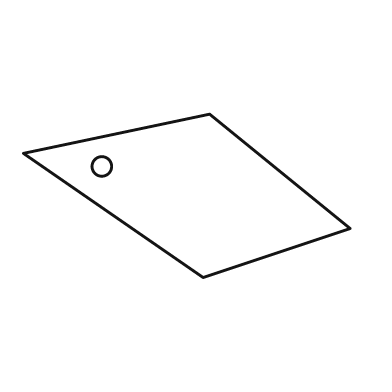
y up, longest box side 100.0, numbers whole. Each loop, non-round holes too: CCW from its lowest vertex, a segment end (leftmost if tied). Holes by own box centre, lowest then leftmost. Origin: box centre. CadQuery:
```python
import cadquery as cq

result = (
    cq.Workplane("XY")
    .moveTo(5.0, -25.0)
    .lineTo(50.0, -10.0)
    .lineTo(7.0, 25.0)
    .lineTo(-50.0, 13.0)
    .close()
    .moveTo(-26.0, 9.0)
    .circle(3.0)
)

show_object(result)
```